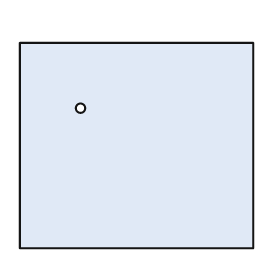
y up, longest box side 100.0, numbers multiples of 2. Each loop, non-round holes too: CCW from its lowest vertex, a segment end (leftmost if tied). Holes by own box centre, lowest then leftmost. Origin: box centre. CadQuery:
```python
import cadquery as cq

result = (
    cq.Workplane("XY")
    .moveTo(-50.0, -44.0)
    .lineTo(50.0, -44.0)
    .lineTo(50.0, 44.0)
    .lineTo(-50.0, 44.0)
    .close()
    .moveTo(-24.0, 16.0)
    .circle(2.0)
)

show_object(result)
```